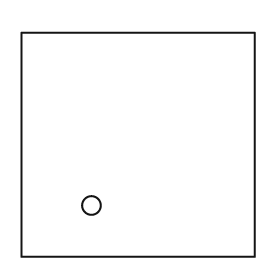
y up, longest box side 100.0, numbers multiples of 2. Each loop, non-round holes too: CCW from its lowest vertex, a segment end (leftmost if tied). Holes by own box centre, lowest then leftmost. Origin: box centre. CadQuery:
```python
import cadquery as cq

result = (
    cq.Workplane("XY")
    .moveTo(-50.0, -48.0)
    .lineTo(50.0, -48.0)
    .lineTo(50.0, 48.0)
    .lineTo(-50.0, 48.0)
    .close()
    .moveTo(-20.0, -26.0)
    .circle(4.0)
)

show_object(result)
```